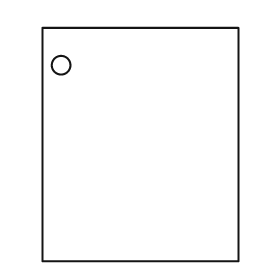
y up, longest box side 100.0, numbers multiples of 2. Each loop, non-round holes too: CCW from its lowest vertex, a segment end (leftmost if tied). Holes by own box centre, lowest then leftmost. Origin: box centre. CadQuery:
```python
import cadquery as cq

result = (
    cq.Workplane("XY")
    .moveTo(-42.0, -50.0)
    .lineTo(42.0, -50.0)
    .lineTo(42.0, 50.0)
    .lineTo(-42.0, 50.0)
    .close()
    .moveTo(-34.0, 34.0)
    .circle(4.0)
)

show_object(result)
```